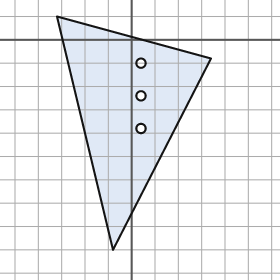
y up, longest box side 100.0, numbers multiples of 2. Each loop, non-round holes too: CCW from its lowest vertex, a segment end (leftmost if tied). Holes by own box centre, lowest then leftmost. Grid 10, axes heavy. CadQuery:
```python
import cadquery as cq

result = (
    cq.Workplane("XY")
    .moveTo(-8.0, -90.0)
    .lineTo(34.0, -8.0)
    .lineTo(-32.0, 10.0)
    .close()
    .moveTo(4.0, -38.0)
    .circle(2.0)
    .moveTo(4.0, -24.0)
    .circle(2.0)
    .moveTo(4.0, -10.0)
    .circle(2.0)
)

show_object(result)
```